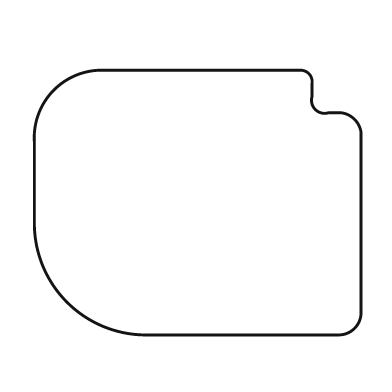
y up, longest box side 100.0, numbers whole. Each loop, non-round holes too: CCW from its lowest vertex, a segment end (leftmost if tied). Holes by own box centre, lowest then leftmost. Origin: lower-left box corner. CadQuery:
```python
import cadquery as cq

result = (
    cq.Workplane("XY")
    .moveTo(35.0, 0.0)
    .lineTo(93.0, 0.0)
    .threePointArc((98.0, 2.0), (100.0, 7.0))
    .lineTo(100.0, 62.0)
    .threePointArc((98.0, 66.0), (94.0, 68.0))
    .lineTo(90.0, 68.0)
    .threePointArc((86.0, 69.0), (85.0, 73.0))
    .lineTo(85.0, 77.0)
    .threePointArc((84.0, 80.0), (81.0, 81.0))
    .lineTo(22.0, 81.0)
    .threePointArc((6.0, 75.0), (0.0, 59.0))
    .lineTo(0.0, 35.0)
    .threePointArc((10.0, 10.0), (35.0, 0.0))
    .close()
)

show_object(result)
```